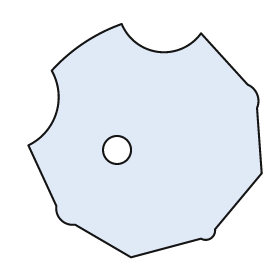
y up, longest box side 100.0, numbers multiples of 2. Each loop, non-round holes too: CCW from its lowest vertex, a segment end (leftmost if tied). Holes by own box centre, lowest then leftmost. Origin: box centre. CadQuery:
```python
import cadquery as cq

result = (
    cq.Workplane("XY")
    .moveTo(-6.0, -50.0)
    .lineTo(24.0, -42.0)
    .threePointArc((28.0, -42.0), (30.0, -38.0))
    .lineTo(50.0, -14.0)
    .lineTo(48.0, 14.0)
    .threePointArc((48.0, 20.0), (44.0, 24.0))
    .lineTo(24.0, 46.0)
    .threePointArc((6.0, 38.0), (-10.0, 50.0))
    .threePointArc((-26.0, 42.0), (-40.0, 30.0))
    .threePointArc((-38.0, 12.0), (-50.0, -2.0))
    .lineTo(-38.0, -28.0)
    .threePointArc((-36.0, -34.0), (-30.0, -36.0))
    .close()
    .moveTo(-12.0, -4.0)
    .circle(6.0)
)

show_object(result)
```